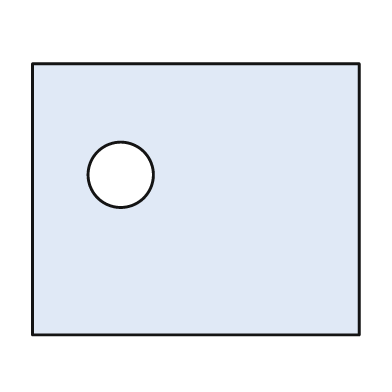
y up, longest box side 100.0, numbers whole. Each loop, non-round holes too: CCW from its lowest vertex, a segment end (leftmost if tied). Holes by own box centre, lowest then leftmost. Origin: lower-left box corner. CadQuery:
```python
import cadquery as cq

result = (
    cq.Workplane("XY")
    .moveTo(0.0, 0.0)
    .lineTo(100.0, 0.0)
    .lineTo(100.0, 83.0)
    .lineTo(0.0, 83.0)
    .close()
    .moveTo(27.0, 49.0)
    .circle(10.0)
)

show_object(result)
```